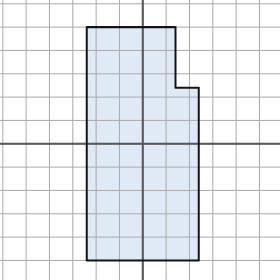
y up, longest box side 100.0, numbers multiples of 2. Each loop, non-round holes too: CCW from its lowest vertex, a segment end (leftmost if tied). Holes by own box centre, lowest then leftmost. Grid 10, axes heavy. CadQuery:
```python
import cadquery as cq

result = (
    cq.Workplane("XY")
    .moveTo(-24.0, -50.0)
    .lineTo(24.0, -50.0)
    .lineTo(24.0, 24.0)
    .lineTo(14.0, 24.0)
    .lineTo(14.0, 50.0)
    .lineTo(-24.0, 50.0)
    .close()
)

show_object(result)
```